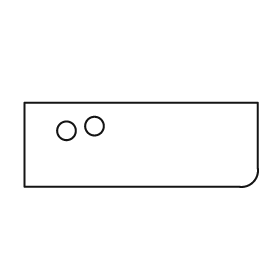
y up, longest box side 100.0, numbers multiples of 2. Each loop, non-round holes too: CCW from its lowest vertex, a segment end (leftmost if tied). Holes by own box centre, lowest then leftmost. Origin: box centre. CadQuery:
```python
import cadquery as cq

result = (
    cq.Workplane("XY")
    .moveTo(-50.0, -18.0)
    .lineTo(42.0, -18.0)
    .threePointArc((48.0, -16.0), (50.0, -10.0))
    .lineTo(50.0, 18.0)
    .lineTo(-50.0, 18.0)
    .close()
    .moveTo(-32.0, 6.0)
    .circle(4.0)
    .moveTo(-20.0, 8.0)
    .circle(4.0)
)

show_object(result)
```